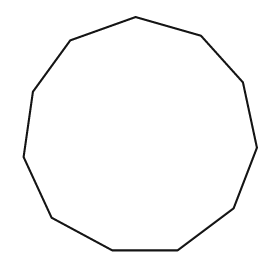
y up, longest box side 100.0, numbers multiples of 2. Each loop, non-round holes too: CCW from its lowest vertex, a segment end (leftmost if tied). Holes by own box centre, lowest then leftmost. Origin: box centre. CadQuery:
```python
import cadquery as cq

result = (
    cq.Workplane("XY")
    .moveTo(-12.0, -50.0)
    .lineTo(16.0, -50.0)
    .lineTo(40.0, -32.0)
    .lineTo(50.0, -6.0)
    .lineTo(44.0, 22.0)
    .lineTo(26.0, 42.0)
    .lineTo(-2.0, 50.0)
    .lineTo(-30.0, 40.0)
    .lineTo(-46.0, 18.0)
    .lineTo(-50.0, -10.0)
    .lineTo(-38.0, -36.0)
    .close()
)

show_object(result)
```